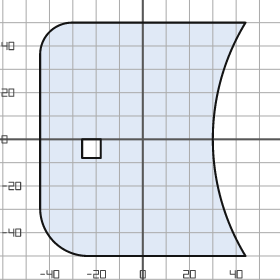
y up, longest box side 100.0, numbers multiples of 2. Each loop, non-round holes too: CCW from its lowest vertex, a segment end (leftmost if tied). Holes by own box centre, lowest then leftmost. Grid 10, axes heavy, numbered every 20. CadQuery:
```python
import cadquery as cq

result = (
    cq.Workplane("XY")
    .moveTo(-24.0, -50.0)
    .lineTo(44.0, -50.0)
    .threePointArc((30.0, 0.0), (44.0, 50.0))
    .lineTo(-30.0, 50.0)
    .threePointArc((-40.0, 46.0), (-44.0, 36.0))
    .lineTo(-44.0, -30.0)
    .threePointArc((-38.0, -44.0), (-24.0, -50.0))
    .close()
    .moveTo(-26.0, -8.0)
    .lineTo(-18.0, -8.0)
    .lineTo(-18.0, 0.0)
    .lineTo(-26.0, 0.0)
    .close()
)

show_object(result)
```